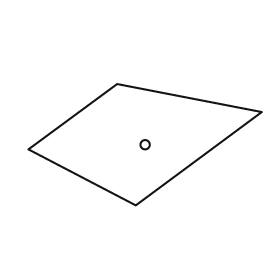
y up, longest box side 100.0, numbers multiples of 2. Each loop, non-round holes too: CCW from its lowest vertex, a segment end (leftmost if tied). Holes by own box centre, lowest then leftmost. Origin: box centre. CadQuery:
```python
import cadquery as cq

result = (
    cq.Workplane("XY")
    .moveTo(-4.0, -26.0)
    .lineTo(50.0, 14.0)
    .lineTo(-12.0, 26.0)
    .lineTo(-50.0, -2.0)
    .close()
    .moveTo(0.0, 0.0)
    .circle(2.0)
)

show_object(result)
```